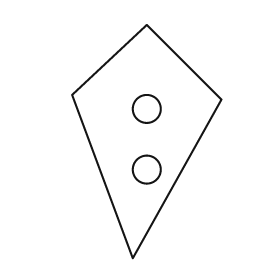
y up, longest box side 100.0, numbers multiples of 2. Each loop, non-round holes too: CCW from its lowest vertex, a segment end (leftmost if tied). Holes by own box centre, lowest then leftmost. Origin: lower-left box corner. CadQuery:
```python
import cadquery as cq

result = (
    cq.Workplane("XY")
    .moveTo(26.0, 0.0)
    .lineTo(64.0, 68.0)
    .lineTo(32.0, 100.0)
    .lineTo(0.0, 70.0)
    .close()
    .moveTo(32.0, 38.0)
    .circle(6.0)
    .moveTo(32.0, 64.0)
    .circle(6.0)
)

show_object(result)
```